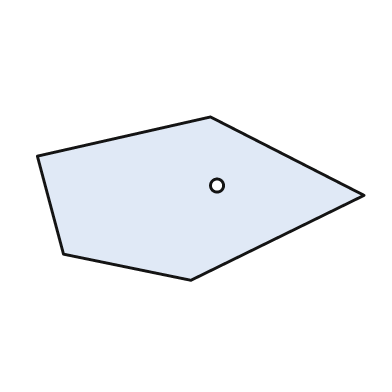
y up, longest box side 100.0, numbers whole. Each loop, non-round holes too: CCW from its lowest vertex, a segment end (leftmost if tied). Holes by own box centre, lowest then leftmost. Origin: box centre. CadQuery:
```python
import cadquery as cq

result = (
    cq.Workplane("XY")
    .moveTo(-3.0, -25.0)
    .lineTo(50.0, 1.0)
    .lineTo(3.0, 25.0)
    .lineTo(-50.0, 13.0)
    .lineTo(-42.0, -17.0)
    .close()
    .moveTo(5.0, 4.0)
    .circle(2.0)
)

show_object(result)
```